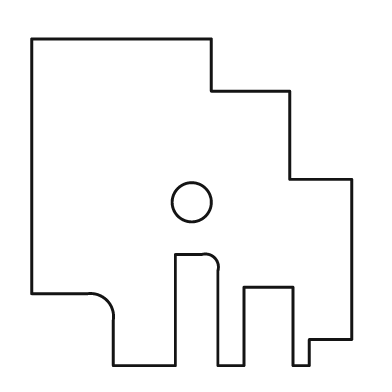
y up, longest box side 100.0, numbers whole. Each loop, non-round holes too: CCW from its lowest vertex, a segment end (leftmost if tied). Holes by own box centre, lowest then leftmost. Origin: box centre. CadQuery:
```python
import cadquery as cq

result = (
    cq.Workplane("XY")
    .moveTo(-24.0, -50.0)
    .lineTo(-5.0, -50.0)
    .lineTo(-5.0, -16.0)
    .lineTo(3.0, -16.0)
    .threePointArc((7.0, -17.0), (8.0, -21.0))
    .lineTo(8.0, -50.0)
    .lineTo(16.0, -50.0)
    .lineTo(16.0, -26.0)
    .lineTo(31.0, -26.0)
    .lineTo(31.0, -50.0)
    .lineTo(36.0, -50.0)
    .lineTo(36.0, -42.0)
    .lineTo(49.0, -42.0)
    .lineTo(49.0, 7.0)
    .lineTo(30.0, 7.0)
    .lineTo(30.0, 34.0)
    .lineTo(6.0, 34.0)
    .lineTo(6.0, 50.0)
    .lineTo(-49.0, 50.0)
    .lineTo(-49.0, -28.0)
    .lineTo(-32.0, -28.0)
    .threePointArc((-26.0, -30.0), (-24.0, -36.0))
    .close()
    .moveTo(0.0, 0.0)
    .circle(6.0)
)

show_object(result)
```